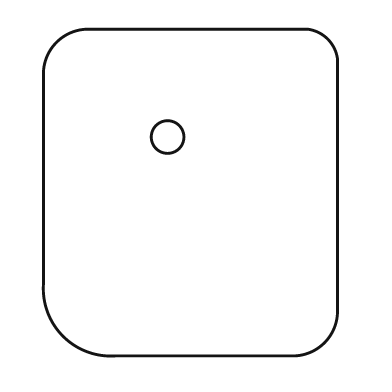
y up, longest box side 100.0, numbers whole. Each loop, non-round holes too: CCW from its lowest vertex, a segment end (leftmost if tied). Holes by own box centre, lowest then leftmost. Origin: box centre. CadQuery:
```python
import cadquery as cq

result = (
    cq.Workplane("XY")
    .moveTo(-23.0, -50.0)
    .lineTo(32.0, -50.0)
    .threePointArc((41.0, -46.0), (45.0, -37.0))
    .lineTo(45.0, 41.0)
    .threePointArc((42.0, 47.0), (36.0, 50.0))
    .lineTo(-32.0, 50.0)
    .threePointArc((-41.0, 46.0), (-45.0, 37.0))
    .lineTo(-45.0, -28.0)
    .threePointArc((-39.0, -44.0), (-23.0, -50.0))
    .close()
    .moveTo(-7.0, 17.0)
    .circle(5.0)
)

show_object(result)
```